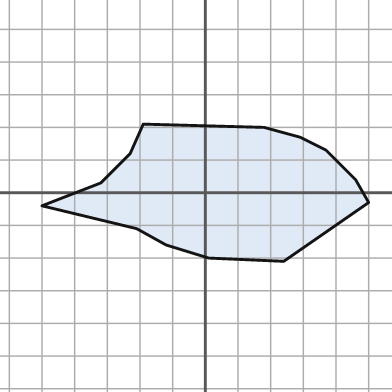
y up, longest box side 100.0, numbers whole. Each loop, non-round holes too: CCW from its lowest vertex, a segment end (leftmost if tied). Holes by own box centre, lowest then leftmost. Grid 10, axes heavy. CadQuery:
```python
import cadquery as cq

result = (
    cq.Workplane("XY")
    .moveTo(24.0, -21.0)
    .lineTo(50.0, -3.0)
    .lineTo(46.0, 4.0)
    .lineTo(37.0, 13.0)
    .lineTo(29.0, 17.0)
    .lineTo(18.0, 20.0)
    .lineTo(-19.0, 21.0)
    .lineTo(-23.0, 12.0)
    .lineTo(-32.0, 3.0)
    .lineTo(-50.0, -4.0)
    .lineTo(-21.0, -11.0)
    .lineTo(-12.0, -16.0)
    .lineTo(1.0, -20.0)
    .close()
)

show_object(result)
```